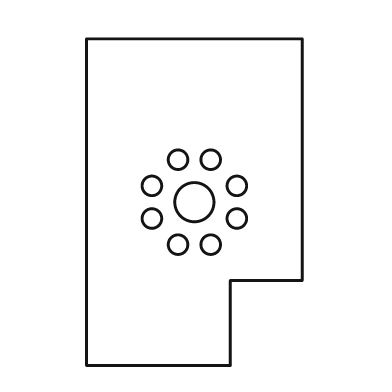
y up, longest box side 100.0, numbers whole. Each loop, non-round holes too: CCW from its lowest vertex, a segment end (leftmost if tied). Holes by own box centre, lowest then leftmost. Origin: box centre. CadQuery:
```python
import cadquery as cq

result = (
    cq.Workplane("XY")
    .moveTo(-33.0, -50.0)
    .lineTo(11.0, -50.0)
    .lineTo(11.0, -24.0)
    .lineTo(33.0, -24.0)
    .lineTo(33.0, 50.0)
    .lineTo(-33.0, 50.0)
    .close()
    .moveTo(-5.0, -13.0)
    .circle(3.0)
    .moveTo(5.0, -13.0)
    .circle(3.0)
    .moveTo(-13.0, -5.0)
    .circle(3.0)
    .moveTo(13.0, -5.0)
    .circle(3.0)
    .moveTo(0.0, 0.0)
    .circle(6.0)
    .moveTo(-13.0, 5.0)
    .circle(3.0)
    .moveTo(13.0, 5.0)
    .circle(3.0)
    .moveTo(-5.0, 13.0)
    .circle(3.0)
    .moveTo(5.0, 13.0)
    .circle(3.0)
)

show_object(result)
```